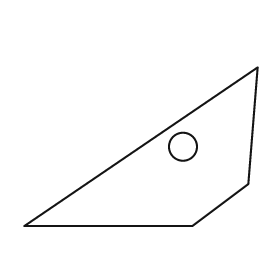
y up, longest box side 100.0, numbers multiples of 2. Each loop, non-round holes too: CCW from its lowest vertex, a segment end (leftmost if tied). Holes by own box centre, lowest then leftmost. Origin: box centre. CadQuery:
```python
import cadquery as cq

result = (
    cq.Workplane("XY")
    .moveTo(-50.0, -34.0)
    .lineTo(22.0, -34.0)
    .lineTo(46.0, -16.0)
    .lineTo(50.0, 34.0)
    .close()
    .moveTo(18.0, 0.0)
    .circle(6.0)
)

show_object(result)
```